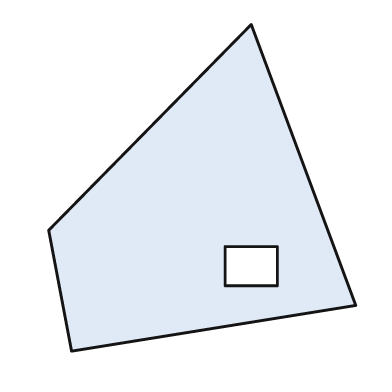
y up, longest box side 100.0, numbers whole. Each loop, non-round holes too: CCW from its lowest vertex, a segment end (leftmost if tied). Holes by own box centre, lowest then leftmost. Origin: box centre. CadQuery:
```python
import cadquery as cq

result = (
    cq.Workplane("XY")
    .moveTo(-40.0, -50.0)
    .lineTo(47.0, -36.0)
    .lineTo(15.0, 50.0)
    .lineTo(-47.0, -13.0)
    .close()
    .moveTo(7.0, -30.0)
    .lineTo(23.0, -30.0)
    .lineTo(23.0, -18.0)
    .lineTo(7.0, -18.0)
    .close()
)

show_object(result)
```